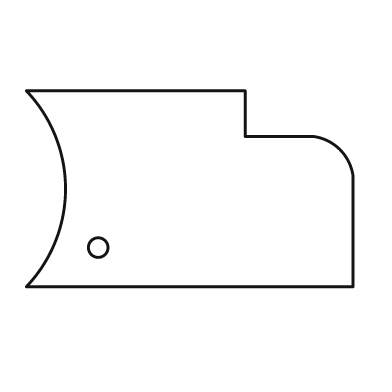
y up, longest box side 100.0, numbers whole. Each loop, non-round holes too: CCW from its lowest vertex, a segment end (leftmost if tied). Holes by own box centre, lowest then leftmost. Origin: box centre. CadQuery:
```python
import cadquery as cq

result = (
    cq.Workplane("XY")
    .moveTo(-50.0, -30.0)
    .lineTo(50.0, -30.0)
    .lineTo(50.0, 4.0)
    .threePointArc((46.0, 12.0), (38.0, 16.0))
    .lineTo(17.0, 16.0)
    .lineTo(17.0, 30.0)
    .lineTo(-50.0, 30.0)
    .threePointArc((-38.0, 0.0), (-50.0, -30.0))
    .close()
    .moveTo(-28.0, -18.0)
    .circle(3.0)
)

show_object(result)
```